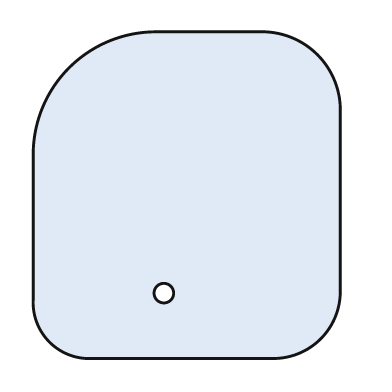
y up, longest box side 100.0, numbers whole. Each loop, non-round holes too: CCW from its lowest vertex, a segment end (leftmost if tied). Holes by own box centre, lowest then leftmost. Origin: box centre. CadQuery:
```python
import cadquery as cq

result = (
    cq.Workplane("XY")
    .moveTo(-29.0, -50.0)
    .lineTo(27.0, -50.0)
    .threePointArc((41.0, -44.0), (47.0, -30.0))
    .lineTo(47.0, 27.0)
    .threePointArc((40.0, 43.0), (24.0, 50.0))
    .lineTo(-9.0, 50.0)
    .threePointArc((-36.0, 39.0), (-47.0, 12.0))
    .lineTo(-47.0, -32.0)
    .threePointArc((-42.0, -45.0), (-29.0, -50.0))
    .close()
    .moveTo(-7.0, -30.0)
    .circle(3.0)
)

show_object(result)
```